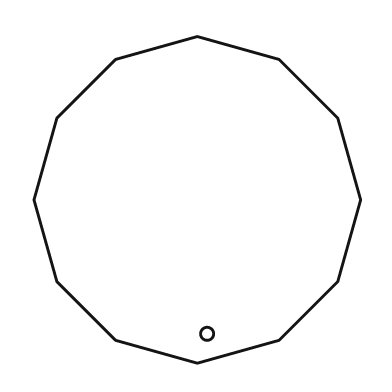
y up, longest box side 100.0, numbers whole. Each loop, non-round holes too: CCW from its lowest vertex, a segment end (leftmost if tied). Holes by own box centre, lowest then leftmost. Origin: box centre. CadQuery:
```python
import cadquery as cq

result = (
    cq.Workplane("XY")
    .moveTo(0.0, -50.0)
    .lineTo(25.0, -43.0)
    .lineTo(43.0, -25.0)
    .lineTo(50.0, 0.0)
    .lineTo(43.0, 25.0)
    .lineTo(25.0, 43.0)
    .lineTo(0.0, 50.0)
    .lineTo(-25.0, 43.0)
    .lineTo(-43.0, 25.0)
    .lineTo(-50.0, 0.0)
    .lineTo(-43.0, -25.0)
    .lineTo(-25.0, -43.0)
    .close()
    .moveTo(3.0, -41.0)
    .circle(2.0)
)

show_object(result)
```